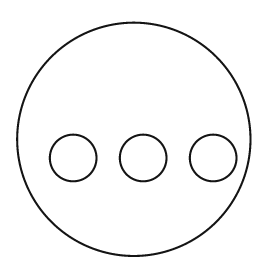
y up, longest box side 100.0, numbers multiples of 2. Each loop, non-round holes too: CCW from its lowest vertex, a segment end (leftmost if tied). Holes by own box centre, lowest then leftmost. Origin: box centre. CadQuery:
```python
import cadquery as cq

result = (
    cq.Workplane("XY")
    .moveTo(0.0, 0.0)
    .circle(50.0)
    .moveTo(-26.0, -8.0)
    .circle(10.0)
    .moveTo(4.0, -8.0)
    .circle(10.0)
    .moveTo(34.0, -8.0)
    .circle(10.0)
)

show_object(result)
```